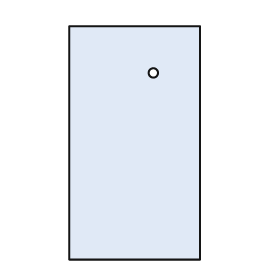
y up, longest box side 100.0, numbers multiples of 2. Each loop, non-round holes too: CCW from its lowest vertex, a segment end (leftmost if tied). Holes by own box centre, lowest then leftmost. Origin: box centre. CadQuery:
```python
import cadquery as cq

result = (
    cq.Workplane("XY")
    .moveTo(-28.0, -50.0)
    .lineTo(28.0, -50.0)
    .lineTo(28.0, 50.0)
    .lineTo(-28.0, 50.0)
    .close()
    .moveTo(8.0, 30.0)
    .circle(2.0)
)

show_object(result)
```